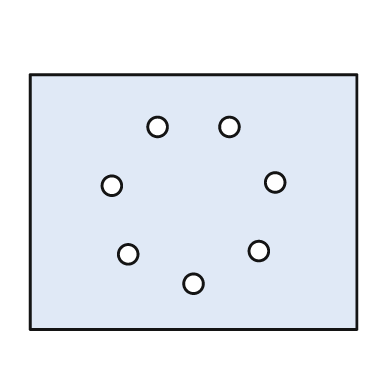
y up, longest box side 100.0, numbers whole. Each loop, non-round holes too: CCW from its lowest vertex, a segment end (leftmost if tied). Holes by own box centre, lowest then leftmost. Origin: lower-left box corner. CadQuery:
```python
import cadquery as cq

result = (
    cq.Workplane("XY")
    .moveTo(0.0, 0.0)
    .lineTo(100.0, 0.0)
    .lineTo(100.0, 78.0)
    .lineTo(0.0, 78.0)
    .close()
    .moveTo(50.0, 14.0)
    .circle(3.0)
    .moveTo(30.0, 23.0)
    .circle(3.0)
    .moveTo(70.0, 24.0)
    .circle(3.0)
    .moveTo(25.0, 44.0)
    .circle(3.0)
    .moveTo(75.0, 45.0)
    .circle(3.0)
    .moveTo(39.0, 62.0)
    .circle(3.0)
    .moveTo(61.0, 62.0)
    .circle(3.0)
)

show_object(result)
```